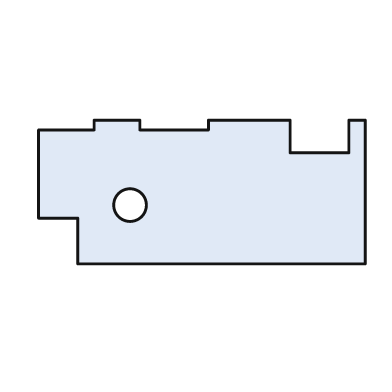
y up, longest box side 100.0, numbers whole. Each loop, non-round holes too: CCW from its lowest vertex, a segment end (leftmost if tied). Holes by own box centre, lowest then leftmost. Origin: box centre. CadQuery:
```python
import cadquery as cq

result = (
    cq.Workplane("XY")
    .moveTo(-38.0, -22.0)
    .lineTo(50.0, -22.0)
    .lineTo(50.0, 22.0)
    .lineTo(45.0, 22.0)
    .lineTo(45.0, 12.0)
    .lineTo(27.0, 12.0)
    .lineTo(27.0, 22.0)
    .lineTo(2.0, 22.0)
    .lineTo(2.0, 19.0)
    .lineTo(-19.0, 19.0)
    .lineTo(-19.0, 22.0)
    .lineTo(-33.0, 22.0)
    .lineTo(-33.0, 19.0)
    .lineTo(-50.0, 19.0)
    .lineTo(-50.0, -8.0)
    .lineTo(-38.0, -8.0)
    .close()
    .moveTo(-22.0, -4.0)
    .circle(5.0)
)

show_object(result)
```